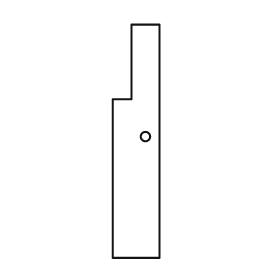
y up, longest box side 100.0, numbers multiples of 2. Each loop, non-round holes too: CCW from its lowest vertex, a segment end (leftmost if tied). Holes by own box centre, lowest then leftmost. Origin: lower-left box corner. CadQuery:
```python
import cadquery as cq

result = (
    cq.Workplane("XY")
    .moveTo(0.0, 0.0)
    .lineTo(20.0, 0.0)
    .lineTo(20.0, 100.0)
    .lineTo(8.0, 100.0)
    .lineTo(8.0, 68.0)
    .lineTo(0.0, 68.0)
    .close()
    .moveTo(14.0, 52.0)
    .circle(2.0)
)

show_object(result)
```